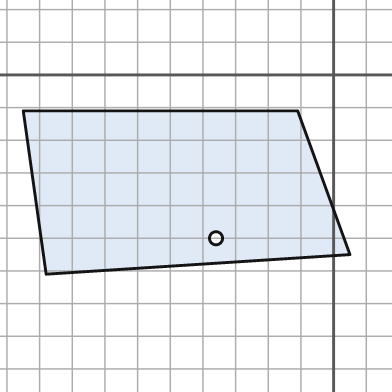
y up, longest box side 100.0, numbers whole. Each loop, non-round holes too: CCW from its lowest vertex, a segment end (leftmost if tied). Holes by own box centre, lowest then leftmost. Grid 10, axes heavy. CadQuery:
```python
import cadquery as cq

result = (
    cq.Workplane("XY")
    .moveTo(-88.0, -61.0)
    .lineTo(5.0, -55.0)
    .lineTo(-11.0, -11.0)
    .lineTo(-95.0, -11.0)
    .close()
    .moveTo(-36.0, -50.0)
    .circle(2.0)
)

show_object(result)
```